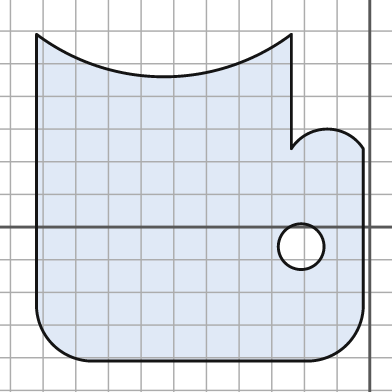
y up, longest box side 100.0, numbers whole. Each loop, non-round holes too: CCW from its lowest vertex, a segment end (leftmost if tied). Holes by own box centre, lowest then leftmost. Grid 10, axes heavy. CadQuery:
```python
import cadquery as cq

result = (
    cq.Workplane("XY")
    .moveTo(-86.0, -41.0)
    .lineTo(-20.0, -41.0)
    .threePointArc((-7.0, -36.0), (-2.0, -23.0))
    .lineTo(-2.0, 24.0)
    .threePointArc((-13.0, 30.0), (-24.0, 24.0))
    .lineTo(-24.0, 59.0)
    .threePointArc((-63.0, 46.0), (-102.0, 59.0))
    .lineTo(-102.0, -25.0)
    .threePointArc((-97.0, -36.0), (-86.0, -41.0))
    .close()
    .moveTo(-21.0, -6.0)
    .circle(7.0)
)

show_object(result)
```